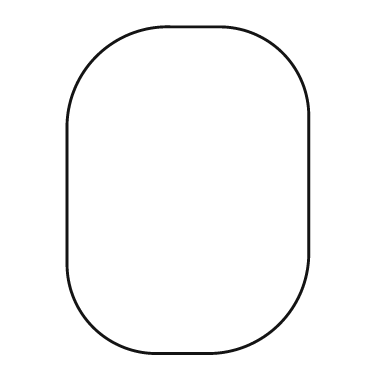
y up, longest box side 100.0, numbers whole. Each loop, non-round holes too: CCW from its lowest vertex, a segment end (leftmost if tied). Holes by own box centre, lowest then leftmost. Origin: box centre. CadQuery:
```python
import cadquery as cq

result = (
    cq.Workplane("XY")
    .moveTo(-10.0, -50.0)
    .lineTo(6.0, -50.0)
    .threePointArc((28.0, -41.0), (37.0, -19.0))
    .lineTo(37.0, 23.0)
    .threePointArc((29.0, 42.0), (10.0, 50.0))
    .lineTo(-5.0, 50.0)
    .threePointArc((-28.0, 41.0), (-37.0, 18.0))
    .lineTo(-37.0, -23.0)
    .threePointArc((-29.0, -42.0), (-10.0, -50.0))
    .close()
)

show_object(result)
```